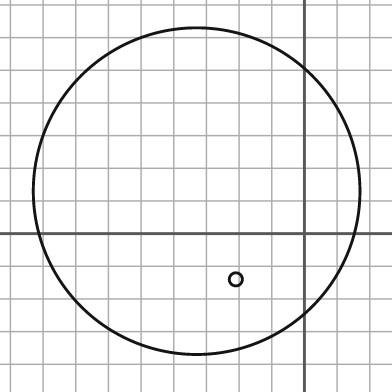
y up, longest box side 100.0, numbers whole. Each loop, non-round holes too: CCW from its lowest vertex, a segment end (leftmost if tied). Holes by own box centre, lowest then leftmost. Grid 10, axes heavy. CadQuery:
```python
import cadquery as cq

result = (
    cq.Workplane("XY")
    .moveTo(-33.0, 13.0)
    .circle(50.0)
    .moveTo(-21.0, -14.0)
    .circle(2.0)
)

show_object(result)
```